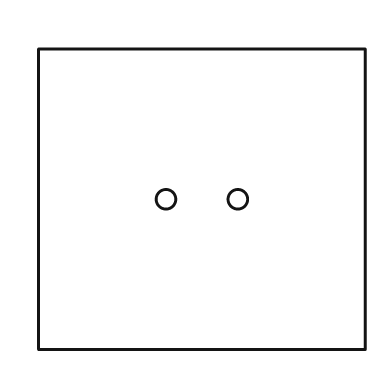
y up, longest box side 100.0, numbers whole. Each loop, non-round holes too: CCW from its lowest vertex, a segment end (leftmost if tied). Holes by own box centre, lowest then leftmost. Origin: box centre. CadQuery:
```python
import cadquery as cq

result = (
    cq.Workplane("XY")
    .moveTo(-50.0, -46.0)
    .lineTo(50.0, -46.0)
    .lineTo(50.0, 46.0)
    .lineTo(-50.0, 46.0)
    .close()
    .moveTo(-11.0, 0.0)
    .circle(3.0)
    .moveTo(11.0, 0.0)
    .circle(3.0)
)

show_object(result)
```